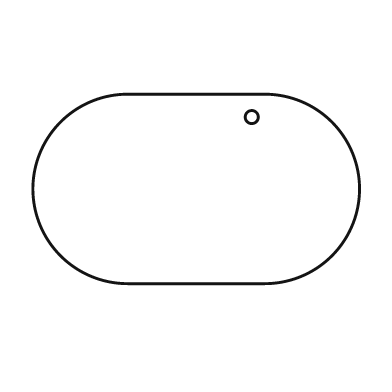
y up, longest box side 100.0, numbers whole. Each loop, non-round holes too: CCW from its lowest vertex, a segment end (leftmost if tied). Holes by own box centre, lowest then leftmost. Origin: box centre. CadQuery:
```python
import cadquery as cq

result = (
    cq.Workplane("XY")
    .moveTo(-21.0, -29.0)
    .lineTo(21.0, -29.0)
    .threePointArc((50.0, 0.0), (21.0, 29.0))
    .lineTo(-21.0, 29.0)
    .threePointArc((-50.0, 0.0), (-21.0, -29.0))
    .close()
    .moveTo(17.0, 22.0)
    .circle(2.0)
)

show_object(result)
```